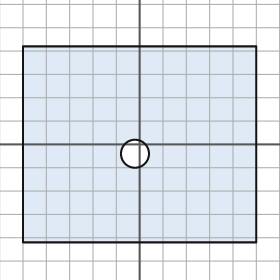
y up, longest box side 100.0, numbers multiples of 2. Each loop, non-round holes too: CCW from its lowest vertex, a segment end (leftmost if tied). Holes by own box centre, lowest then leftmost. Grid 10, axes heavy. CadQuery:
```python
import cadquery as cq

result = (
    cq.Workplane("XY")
    .moveTo(-50.0, -42.0)
    .lineTo(50.0, -42.0)
    .lineTo(50.0, 42.0)
    .lineTo(-50.0, 42.0)
    .close()
    .moveTo(-2.0, -4.0)
    .circle(6.0)
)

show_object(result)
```